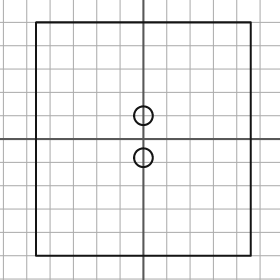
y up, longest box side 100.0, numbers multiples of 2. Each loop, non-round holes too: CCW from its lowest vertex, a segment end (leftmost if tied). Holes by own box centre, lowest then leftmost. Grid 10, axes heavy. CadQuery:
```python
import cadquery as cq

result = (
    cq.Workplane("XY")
    .moveTo(-46.0, -50.0)
    .lineTo(46.0, -50.0)
    .lineTo(46.0, 50.0)
    .lineTo(-46.0, 50.0)
    .close()
    .moveTo(0.0, -8.0)
    .circle(4.0)
    .moveTo(0.0, 10.0)
    .circle(4.0)
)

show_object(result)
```